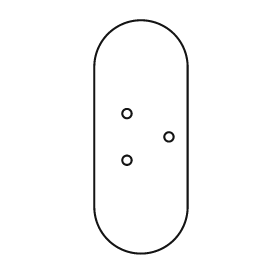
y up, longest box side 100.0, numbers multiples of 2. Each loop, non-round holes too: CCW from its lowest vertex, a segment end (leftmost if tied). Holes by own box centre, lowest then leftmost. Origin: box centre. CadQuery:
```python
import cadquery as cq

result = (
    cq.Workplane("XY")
    .moveTo(-20.0, -30.0)
    .threePointArc((0.0, -50.0), (20.0, -30.0))
    .lineTo(20.0, 30.0)
    .threePointArc((0.0, 50.0), (-20.0, 30.0))
    .close()
    .moveTo(-6.0, -10.0)
    .circle(2.0)
    .moveTo(12.0, 0.0)
    .circle(2.0)
    .moveTo(-6.0, 10.0)
    .circle(2.0)
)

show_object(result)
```